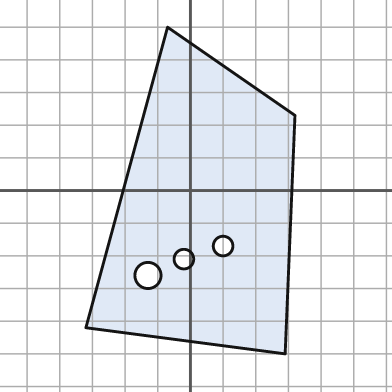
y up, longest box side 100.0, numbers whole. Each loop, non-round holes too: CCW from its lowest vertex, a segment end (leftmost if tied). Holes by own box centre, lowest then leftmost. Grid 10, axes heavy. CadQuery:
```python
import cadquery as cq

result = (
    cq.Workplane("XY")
    .moveTo(29.0, -50.0)
    .lineTo(32.0, 23.0)
    .lineTo(-7.0, 50.0)
    .lineTo(-32.0, -42.0)
    .close()
    .moveTo(-13.0, -26.0)
    .circle(4.0)
    .moveTo(-2.0, -21.0)
    .circle(3.0)
    .moveTo(10.0, -17.0)
    .circle(3.0)
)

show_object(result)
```